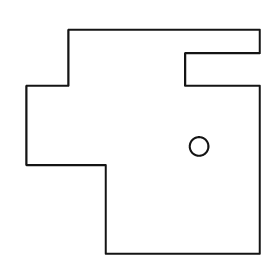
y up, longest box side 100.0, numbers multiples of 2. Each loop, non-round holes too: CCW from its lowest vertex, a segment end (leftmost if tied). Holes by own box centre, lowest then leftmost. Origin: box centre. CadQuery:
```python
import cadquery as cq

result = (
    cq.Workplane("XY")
    .moveTo(-16.0, -48.0)
    .lineTo(50.0, -48.0)
    .lineTo(50.0, 24.0)
    .lineTo(18.0, 24.0)
    .lineTo(18.0, 38.0)
    .lineTo(50.0, 38.0)
    .lineTo(50.0, 48.0)
    .lineTo(-32.0, 48.0)
    .lineTo(-32.0, 24.0)
    .lineTo(-50.0, 24.0)
    .lineTo(-50.0, -10.0)
    .lineTo(-16.0, -10.0)
    .close()
    .moveTo(24.0, -2.0)
    .circle(4.0)
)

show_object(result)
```